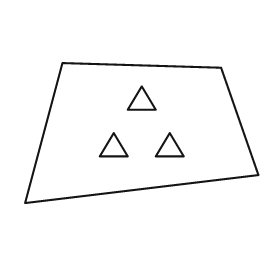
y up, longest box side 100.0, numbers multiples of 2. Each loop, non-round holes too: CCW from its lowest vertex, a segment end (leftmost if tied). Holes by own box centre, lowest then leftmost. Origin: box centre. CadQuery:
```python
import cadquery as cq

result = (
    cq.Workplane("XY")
    .moveTo(-50.0, -30.0)
    .lineTo(50.0, -18.0)
    .lineTo(34.0, 28.0)
    .lineTo(-34.0, 30.0)
    .close()
    .moveTo(-18.0, -10.0)
    .lineTo(-6.0, -10.0)
    .lineTo(-12.0, 0.0)
    .close()
    .moveTo(6.0, -10.0)
    .lineTo(18.0, -10.0)
    .lineTo(12.0, 0.0)
    .close()
    .moveTo(-6.0, 10.0)
    .lineTo(6.0, 10.0)
    .lineTo(0.0, 20.0)
    .close()
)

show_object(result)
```